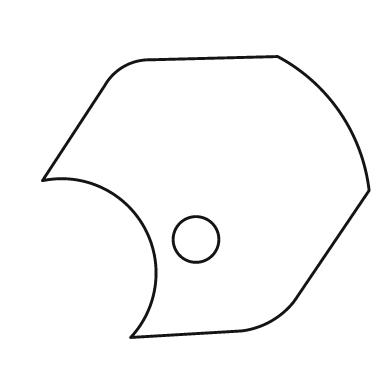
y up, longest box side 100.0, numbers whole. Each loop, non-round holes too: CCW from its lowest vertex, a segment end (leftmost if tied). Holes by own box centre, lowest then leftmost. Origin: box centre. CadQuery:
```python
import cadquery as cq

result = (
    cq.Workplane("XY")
    .moveTo(-23.0, -43.0)
    .lineTo(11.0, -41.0)
    .threePointArc((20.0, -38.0), (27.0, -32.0))
    .lineTo(50.0, 2.0)
    .threePointArc((41.0, 26.0), (22.0, 43.0))
    .lineTo(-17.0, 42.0)
    .threePointArc((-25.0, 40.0), (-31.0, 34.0))
    .lineTo(-50.0, 5.0)
    .threePointArc((-19.0, -9.0), (-23.0, -43.0))
    .close()
    .moveTo(-3.0, -13.0)
    .circle(7.0)
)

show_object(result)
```